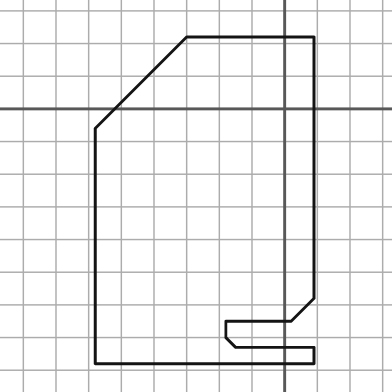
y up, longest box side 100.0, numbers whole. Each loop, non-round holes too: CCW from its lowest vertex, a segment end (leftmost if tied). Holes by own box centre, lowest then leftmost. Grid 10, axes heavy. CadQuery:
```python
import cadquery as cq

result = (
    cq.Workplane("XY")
    .moveTo(-58.0, -78.0)
    .lineTo(9.0, -78.0)
    .lineTo(9.0, -73.0)
    .lineTo(-15.0, -73.0)
    .lineTo(-18.0, -70.0)
    .lineTo(-18.0, -65.0)
    .lineTo(2.0, -65.0)
    .lineTo(9.0, -58.0)
    .lineTo(9.0, 22.0)
    .lineTo(-30.0, 22.0)
    .lineTo(-58.0, -6.0)
    .close()
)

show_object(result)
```